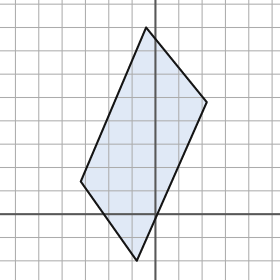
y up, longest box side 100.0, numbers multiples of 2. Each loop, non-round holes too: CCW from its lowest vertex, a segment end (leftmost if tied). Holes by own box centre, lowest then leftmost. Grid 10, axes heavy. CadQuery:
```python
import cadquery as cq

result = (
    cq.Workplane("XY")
    .moveTo(-8.0, -20.0)
    .lineTo(22.0, 48.0)
    .lineTo(-4.0, 80.0)
    .lineTo(-32.0, 14.0)
    .close()
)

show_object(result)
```